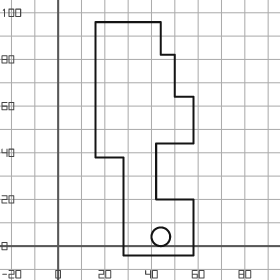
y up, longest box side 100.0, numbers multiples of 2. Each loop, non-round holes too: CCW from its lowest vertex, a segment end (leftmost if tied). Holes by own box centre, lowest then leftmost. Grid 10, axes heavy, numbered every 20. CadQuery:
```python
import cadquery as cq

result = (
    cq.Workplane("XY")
    .moveTo(28.0, -4.0)
    .lineTo(58.0, -4.0)
    .lineTo(58.0, 20.0)
    .lineTo(42.0, 20.0)
    .lineTo(42.0, 44.0)
    .lineTo(58.0, 44.0)
    .lineTo(58.0, 64.0)
    .lineTo(50.0, 64.0)
    .lineTo(50.0, 82.0)
    .lineTo(44.0, 82.0)
    .lineTo(44.0, 96.0)
    .lineTo(16.0, 96.0)
    .lineTo(16.0, 38.0)
    .lineTo(28.0, 38.0)
    .close()
    .moveTo(44.0, 4.0)
    .circle(4.0)
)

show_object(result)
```